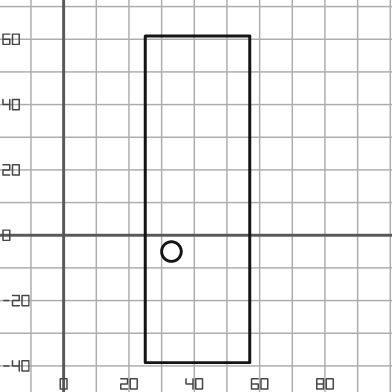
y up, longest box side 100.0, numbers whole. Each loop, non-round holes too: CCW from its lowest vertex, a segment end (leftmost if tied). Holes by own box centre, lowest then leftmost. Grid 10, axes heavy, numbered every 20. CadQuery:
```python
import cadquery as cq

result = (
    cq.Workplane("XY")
    .moveTo(25.0, -39.0)
    .lineTo(57.0, -39.0)
    .lineTo(57.0, 61.0)
    .lineTo(25.0, 61.0)
    .close()
    .moveTo(33.0, -5.0)
    .circle(3.0)
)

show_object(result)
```